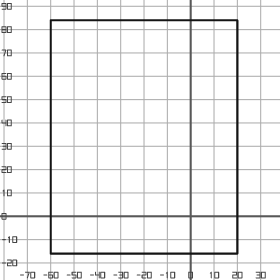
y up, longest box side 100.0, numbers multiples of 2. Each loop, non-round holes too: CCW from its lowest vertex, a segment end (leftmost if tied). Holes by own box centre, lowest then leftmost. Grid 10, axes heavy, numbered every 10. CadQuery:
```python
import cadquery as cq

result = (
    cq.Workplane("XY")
    .moveTo(-60.0, -16.0)
    .lineTo(20.0, -16.0)
    .lineTo(20.0, 84.0)
    .lineTo(-60.0, 84.0)
    .close()
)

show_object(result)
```